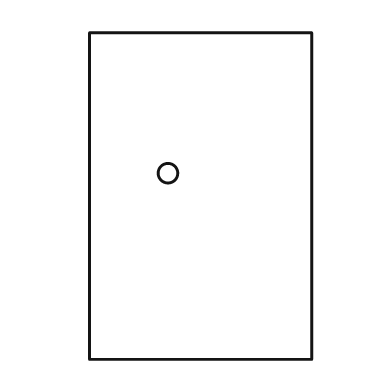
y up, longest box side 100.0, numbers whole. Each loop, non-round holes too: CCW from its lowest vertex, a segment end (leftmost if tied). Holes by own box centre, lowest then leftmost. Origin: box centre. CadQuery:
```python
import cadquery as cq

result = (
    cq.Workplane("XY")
    .moveTo(-34.0, -50.0)
    .lineTo(34.0, -50.0)
    .lineTo(34.0, 50.0)
    .lineTo(-34.0, 50.0)
    .close()
    .moveTo(-10.0, 7.0)
    .circle(3.0)
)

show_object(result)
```